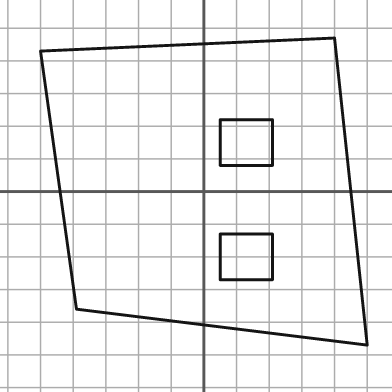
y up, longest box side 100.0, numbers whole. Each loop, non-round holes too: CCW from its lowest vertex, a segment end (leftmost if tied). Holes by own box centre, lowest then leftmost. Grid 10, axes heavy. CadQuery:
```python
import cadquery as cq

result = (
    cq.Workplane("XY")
    .moveTo(50.0, -47.0)
    .lineTo(40.0, 47.0)
    .lineTo(-50.0, 43.0)
    .lineTo(-39.0, -36.0)
    .close()
    .moveTo(5.0, -27.0)
    .lineTo(21.0, -27.0)
    .lineTo(21.0, -13.0)
    .lineTo(5.0, -13.0)
    .close()
    .moveTo(5.0, 8.0)
    .lineTo(21.0, 8.0)
    .lineTo(21.0, 22.0)
    .lineTo(5.0, 22.0)
    .close()
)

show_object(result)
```